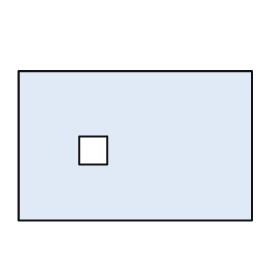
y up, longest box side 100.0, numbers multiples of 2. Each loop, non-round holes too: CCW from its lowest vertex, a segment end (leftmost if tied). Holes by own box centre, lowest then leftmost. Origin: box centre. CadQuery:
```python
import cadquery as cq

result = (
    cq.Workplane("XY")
    .moveTo(-50.0, -32.0)
    .lineTo(50.0, -32.0)
    .lineTo(50.0, 32.0)
    .lineTo(-50.0, 32.0)
    .close()
    .moveTo(-24.0, -8.0)
    .lineTo(-12.0, -8.0)
    .lineTo(-12.0, 4.0)
    .lineTo(-24.0, 4.0)
    .close()
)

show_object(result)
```